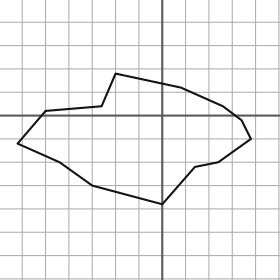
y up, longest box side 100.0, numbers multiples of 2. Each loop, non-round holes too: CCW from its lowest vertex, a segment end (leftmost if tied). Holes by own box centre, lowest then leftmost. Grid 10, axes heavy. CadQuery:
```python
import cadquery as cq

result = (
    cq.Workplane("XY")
    .moveTo(0.0, -38.0)
    .lineTo(14.0, -22.0)
    .lineTo(24.0, -20.0)
    .lineTo(38.0, -10.0)
    .lineTo(34.0, -2.0)
    .lineTo(26.0, 4.0)
    .lineTo(8.0, 12.0)
    .lineTo(-20.0, 18.0)
    .lineTo(-26.0, 4.0)
    .lineTo(-50.0, 2.0)
    .lineTo(-62.0, -12.0)
    .lineTo(-44.0, -20.0)
    .lineTo(-30.0, -30.0)
    .close()
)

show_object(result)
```